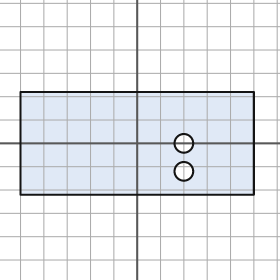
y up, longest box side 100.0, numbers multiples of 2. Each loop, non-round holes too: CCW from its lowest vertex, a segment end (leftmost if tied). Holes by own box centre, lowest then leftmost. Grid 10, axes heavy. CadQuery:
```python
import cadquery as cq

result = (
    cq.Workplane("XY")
    .moveTo(-50.0, -22.0)
    .lineTo(50.0, -22.0)
    .lineTo(50.0, 22.0)
    .lineTo(-50.0, 22.0)
    .close()
    .moveTo(20.0, -12.0)
    .circle(4.0)
    .moveTo(20.0, 0.0)
    .circle(4.0)
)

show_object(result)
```